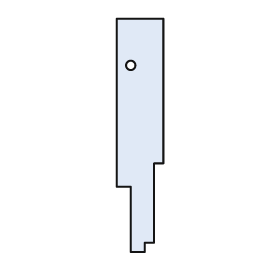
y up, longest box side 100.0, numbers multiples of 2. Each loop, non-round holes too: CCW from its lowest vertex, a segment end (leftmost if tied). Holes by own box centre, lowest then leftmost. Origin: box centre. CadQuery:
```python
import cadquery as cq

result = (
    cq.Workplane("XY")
    .moveTo(-4.0, -50.0)
    .lineTo(2.0, -50.0)
    .lineTo(2.0, -46.0)
    .lineTo(6.0, -46.0)
    .lineTo(6.0, -12.0)
    .lineTo(10.0, -12.0)
    .lineTo(10.0, 50.0)
    .lineTo(-10.0, 50.0)
    .lineTo(-10.0, -22.0)
    .lineTo(-4.0, -22.0)
    .close()
    .moveTo(-4.0, 30.0)
    .circle(2.0)
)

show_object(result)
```